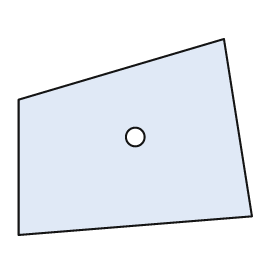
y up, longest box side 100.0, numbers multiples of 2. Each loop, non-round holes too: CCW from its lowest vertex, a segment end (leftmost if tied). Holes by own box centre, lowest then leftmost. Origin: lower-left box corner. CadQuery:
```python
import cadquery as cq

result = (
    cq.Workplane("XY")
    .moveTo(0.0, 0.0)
    .lineTo(100.0, 8.0)
    .lineTo(88.0, 84.0)
    .lineTo(0.0, 58.0)
    .close()
    .moveTo(50.0, 42.0)
    .circle(4.0)
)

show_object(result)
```